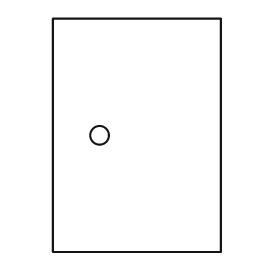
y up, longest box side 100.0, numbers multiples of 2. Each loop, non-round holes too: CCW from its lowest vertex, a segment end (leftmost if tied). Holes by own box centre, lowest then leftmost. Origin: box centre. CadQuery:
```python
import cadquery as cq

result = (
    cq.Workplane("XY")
    .moveTo(-36.0, -50.0)
    .lineTo(36.0, -50.0)
    .lineTo(36.0, 50.0)
    .lineTo(-36.0, 50.0)
    .close()
    .moveTo(-16.0, 0.0)
    .circle(4.0)
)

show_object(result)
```